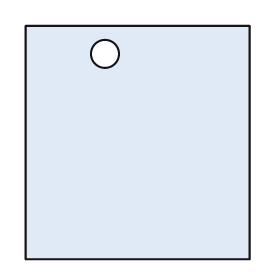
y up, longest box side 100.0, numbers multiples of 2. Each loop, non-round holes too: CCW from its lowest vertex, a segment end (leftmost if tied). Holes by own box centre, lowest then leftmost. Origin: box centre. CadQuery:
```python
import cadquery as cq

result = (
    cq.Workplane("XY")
    .moveTo(-48.0, -50.0)
    .lineTo(48.0, -50.0)
    .lineTo(48.0, 50.0)
    .lineTo(-48.0, 50.0)
    .close()
    .moveTo(-14.0, 38.0)
    .circle(6.0)
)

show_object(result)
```